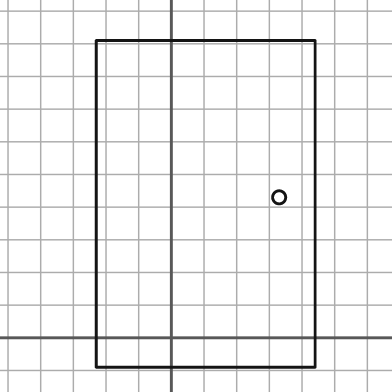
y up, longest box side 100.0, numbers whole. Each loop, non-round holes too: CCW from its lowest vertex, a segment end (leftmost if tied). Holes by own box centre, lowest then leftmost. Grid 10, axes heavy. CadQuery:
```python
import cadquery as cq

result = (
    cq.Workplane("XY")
    .moveTo(-23.0, -9.0)
    .lineTo(44.0, -9.0)
    .lineTo(44.0, 91.0)
    .lineTo(-23.0, 91.0)
    .close()
    .moveTo(33.0, 43.0)
    .circle(2.0)
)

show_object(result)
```